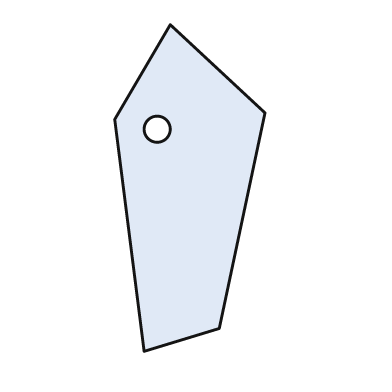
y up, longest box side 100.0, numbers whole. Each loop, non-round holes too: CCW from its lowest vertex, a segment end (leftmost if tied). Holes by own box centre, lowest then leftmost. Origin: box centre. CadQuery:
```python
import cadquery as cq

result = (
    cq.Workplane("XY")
    .moveTo(-14.0, -50.0)
    .lineTo(9.0, -43.0)
    .lineTo(23.0, 23.0)
    .lineTo(-6.0, 50.0)
    .lineTo(-23.0, 21.0)
    .close()
    .moveTo(-10.0, 18.0)
    .circle(4.0)
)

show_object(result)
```